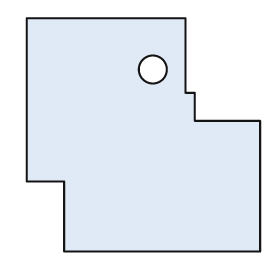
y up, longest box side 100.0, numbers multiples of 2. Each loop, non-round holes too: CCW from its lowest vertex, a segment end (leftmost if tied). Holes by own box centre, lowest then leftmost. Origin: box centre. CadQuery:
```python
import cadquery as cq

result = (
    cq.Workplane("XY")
    .moveTo(-34.0, -50.0)
    .lineTo(50.0, -50.0)
    .lineTo(50.0, 6.0)
    .lineTo(22.0, 6.0)
    .lineTo(22.0, 18.0)
    .lineTo(18.0, 18.0)
    .lineTo(18.0, 50.0)
    .lineTo(-50.0, 50.0)
    .lineTo(-50.0, -20.0)
    .lineTo(-34.0, -20.0)
    .close()
    .moveTo(4.0, 28.0)
    .circle(6.0)
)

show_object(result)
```